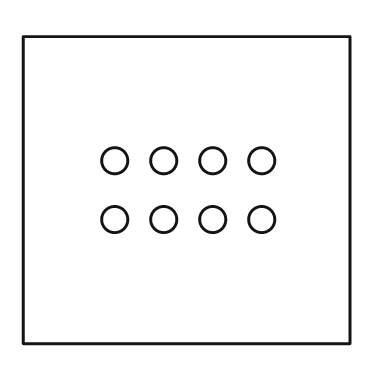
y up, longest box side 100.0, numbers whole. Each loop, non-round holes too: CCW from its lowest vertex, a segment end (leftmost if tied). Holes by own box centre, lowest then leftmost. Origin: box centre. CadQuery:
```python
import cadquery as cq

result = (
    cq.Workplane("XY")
    .moveTo(-50.0, -47.0)
    .lineTo(50.0, -47.0)
    .lineTo(50.0, 47.0)
    .lineTo(-50.0, 47.0)
    .close()
    .moveTo(-22.0, -9.0)
    .circle(4.0)
    .moveTo(-7.0, -9.0)
    .circle(4.0)
    .moveTo(8.0, -9.0)
    .circle(4.0)
    .moveTo(23.0, -9.0)
    .circle(4.0)
    .moveTo(-22.0, 9.0)
    .circle(4.0)
    .moveTo(-7.0, 9.0)
    .circle(4.0)
    .moveTo(8.0, 9.0)
    .circle(4.0)
    .moveTo(23.0, 9.0)
    .circle(4.0)
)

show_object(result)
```